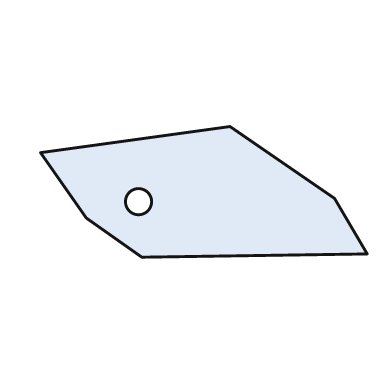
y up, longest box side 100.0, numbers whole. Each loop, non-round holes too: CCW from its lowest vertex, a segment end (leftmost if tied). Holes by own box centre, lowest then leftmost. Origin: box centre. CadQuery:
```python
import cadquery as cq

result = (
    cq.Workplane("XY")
    .moveTo(-19.0, -20.0)
    .lineTo(50.0, -19.0)
    .lineTo(40.0, -2.0)
    .lineTo(8.0, 20.0)
    .lineTo(-50.0, 12.0)
    .lineTo(-36.0, -8.0)
    .close()
    .moveTo(-20.0, -3.0)
    .circle(4.0)
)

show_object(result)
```